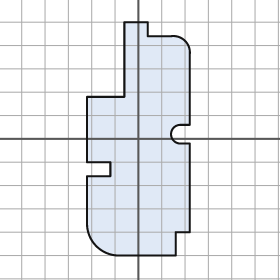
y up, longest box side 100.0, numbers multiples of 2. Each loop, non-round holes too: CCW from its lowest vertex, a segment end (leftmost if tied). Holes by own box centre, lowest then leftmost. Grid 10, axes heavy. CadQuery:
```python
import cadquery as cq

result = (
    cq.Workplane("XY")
    .moveTo(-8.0, -50.0)
    .lineTo(16.0, -50.0)
    .lineTo(16.0, -40.0)
    .lineTo(22.0, -40.0)
    .lineTo(22.0, -2.0)
    .lineTo(18.0, -2.0)
    .threePointArc((14.0, 2.0), (18.0, 6.0))
    .lineTo(22.0, 6.0)
    .lineTo(22.0, 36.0)
    .threePointArc((20.0, 42.0), (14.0, 44.0))
    .lineTo(4.0, 44.0)
    .lineTo(4.0, 50.0)
    .lineTo(-6.0, 50.0)
    .lineTo(-6.0, 18.0)
    .lineTo(-22.0, 18.0)
    .lineTo(-22.0, -10.0)
    .lineTo(-12.0, -10.0)
    .lineTo(-12.0, -16.0)
    .lineTo(-22.0, -16.0)
    .lineTo(-22.0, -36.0)
    .threePointArc((-18.0, -46.0), (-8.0, -50.0))
    .close()
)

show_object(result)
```